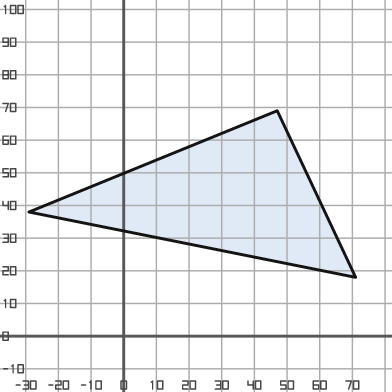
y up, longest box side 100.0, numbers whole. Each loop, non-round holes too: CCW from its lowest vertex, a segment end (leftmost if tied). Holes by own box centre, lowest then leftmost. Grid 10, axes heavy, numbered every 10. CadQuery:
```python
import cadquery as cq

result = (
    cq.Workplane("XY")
    .moveTo(71.0, 18.0)
    .lineTo(47.0, 69.0)
    .lineTo(-29.0, 38.0)
    .close()
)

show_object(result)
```